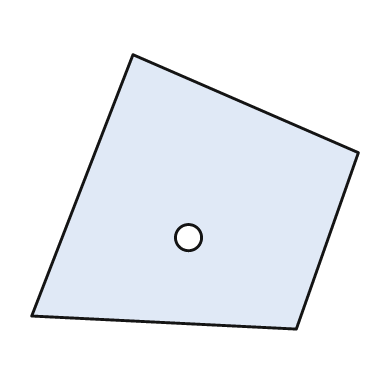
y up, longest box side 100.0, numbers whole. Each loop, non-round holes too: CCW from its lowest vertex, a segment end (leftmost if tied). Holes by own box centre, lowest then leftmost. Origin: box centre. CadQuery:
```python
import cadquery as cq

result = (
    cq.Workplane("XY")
    .moveTo(31.0, -42.0)
    .lineTo(50.0, 12.0)
    .lineTo(-19.0, 42.0)
    .lineTo(-50.0, -38.0)
    .close()
    .moveTo(-2.0, -14.0)
    .circle(4.0)
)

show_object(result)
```